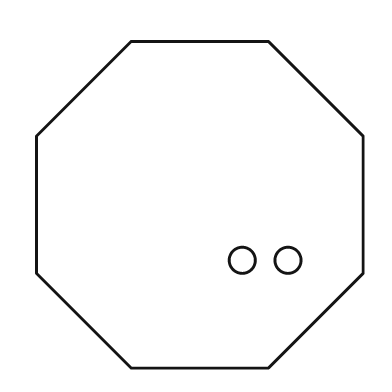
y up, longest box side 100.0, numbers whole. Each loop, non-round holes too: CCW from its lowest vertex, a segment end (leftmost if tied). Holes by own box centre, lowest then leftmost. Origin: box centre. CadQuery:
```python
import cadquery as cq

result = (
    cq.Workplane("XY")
    .moveTo(-21.0, -50.0)
    .lineTo(21.0, -50.0)
    .lineTo(50.0, -21.0)
    .lineTo(50.0, 21.0)
    .lineTo(21.0, 50.0)
    .lineTo(-21.0, 50.0)
    .lineTo(-50.0, 21.0)
    .lineTo(-50.0, -21.0)
    .close()
    .moveTo(13.0, -17.0)
    .circle(4.0)
    .moveTo(27.0, -17.0)
    .circle(4.0)
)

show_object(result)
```